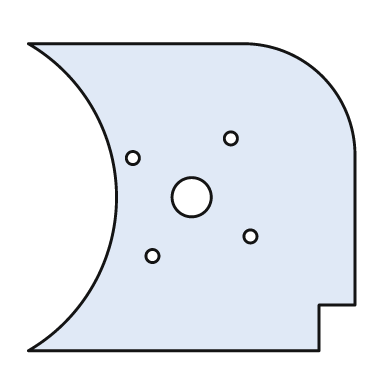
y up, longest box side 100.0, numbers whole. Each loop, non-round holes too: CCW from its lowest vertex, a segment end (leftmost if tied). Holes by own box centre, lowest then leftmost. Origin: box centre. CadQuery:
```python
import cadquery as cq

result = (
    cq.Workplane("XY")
    .moveTo(-50.0, -47.0)
    .lineTo(39.0, -47.0)
    .lineTo(39.0, -33.0)
    .lineTo(50.0, -33.0)
    .lineTo(50.0, 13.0)
    .threePointArc((40.0, 37.0), (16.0, 47.0))
    .lineTo(-50.0, 47.0)
    .threePointArc((-23.0, 0.0), (-50.0, -47.0))
    .close()
    .moveTo(-12.0, -18.0)
    .circle(2.0)
    .moveTo(18.0, -12.0)
    .circle(2.0)
    .moveTo(0.0, 0.0)
    .circle(6.0)
    .moveTo(-18.0, 12.0)
    .circle(2.0)
    .moveTo(12.0, 18.0)
    .circle(2.0)
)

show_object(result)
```